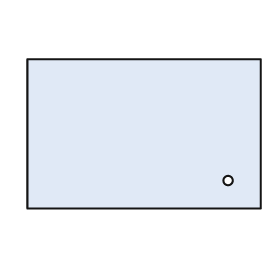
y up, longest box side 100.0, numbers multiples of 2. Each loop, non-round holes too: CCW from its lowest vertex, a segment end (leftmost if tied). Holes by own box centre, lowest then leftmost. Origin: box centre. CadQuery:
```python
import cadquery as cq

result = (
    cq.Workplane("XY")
    .moveTo(-50.0, -32.0)
    .lineTo(50.0, -32.0)
    .lineTo(50.0, 32.0)
    .lineTo(-50.0, 32.0)
    .close()
    .moveTo(36.0, -20.0)
    .circle(2.0)
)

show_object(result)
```